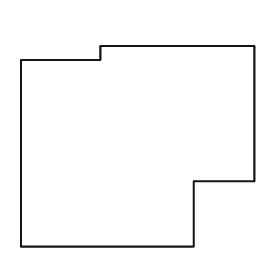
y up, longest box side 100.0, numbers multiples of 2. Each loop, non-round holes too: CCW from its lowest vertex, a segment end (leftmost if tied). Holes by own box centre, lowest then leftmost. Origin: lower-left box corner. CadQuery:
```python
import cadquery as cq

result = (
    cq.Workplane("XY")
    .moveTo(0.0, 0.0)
    .lineTo(74.0, 0.0)
    .lineTo(74.0, 28.0)
    .lineTo(100.0, 28.0)
    .lineTo(100.0, 86.0)
    .lineTo(34.0, 86.0)
    .lineTo(34.0, 80.0)
    .lineTo(0.0, 80.0)
    .close()
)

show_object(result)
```